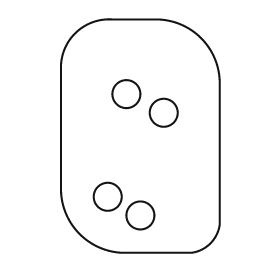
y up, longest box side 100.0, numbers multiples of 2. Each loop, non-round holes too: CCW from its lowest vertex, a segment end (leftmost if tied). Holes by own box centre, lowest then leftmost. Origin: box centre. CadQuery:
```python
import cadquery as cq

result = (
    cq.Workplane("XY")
    .moveTo(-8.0, -50.0)
    .lineTo(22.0, -50.0)
    .threePointArc((30.0, -46.0), (34.0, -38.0))
    .lineTo(34.0, 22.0)
    .threePointArc((26.0, 42.0), (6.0, 50.0))
    .lineTo(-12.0, 50.0)
    .threePointArc((-28.0, 44.0), (-34.0, 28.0))
    .lineTo(-34.0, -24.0)
    .threePointArc((-26.0, -42.0), (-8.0, -50.0))
    .close()
    .moveTo(0.0, -34.0)
    .circle(6.0)
    .moveTo(-14.0, -26.0)
    .circle(6.0)
    .moveTo(10.0, 10.0)
    .circle(6.0)
    .moveTo(-6.0, 18.0)
    .circle(6.0)
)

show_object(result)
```